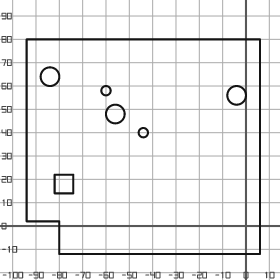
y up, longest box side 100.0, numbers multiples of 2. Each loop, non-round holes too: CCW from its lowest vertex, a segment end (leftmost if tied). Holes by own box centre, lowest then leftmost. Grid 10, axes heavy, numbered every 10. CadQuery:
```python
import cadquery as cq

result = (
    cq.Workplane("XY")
    .moveTo(-80.0, -12.0)
    .lineTo(6.0, -12.0)
    .lineTo(6.0, 80.0)
    .lineTo(-94.0, 80.0)
    .lineTo(-94.0, 2.0)
    .lineTo(-80.0, 2.0)
    .close()
    .moveTo(-82.0, 14.0)
    .lineTo(-74.0, 14.0)
    .lineTo(-74.0, 22.0)
    .lineTo(-82.0, 22.0)
    .close()
    .moveTo(-44.0, 40.0)
    .circle(2.0)
    .moveTo(-56.0, 48.0)
    .circle(4.0)
    .moveTo(-4.0, 56.0)
    .circle(4.0)
    .moveTo(-60.0, 58.0)
    .circle(2.0)
    .moveTo(-84.0, 64.0)
    .circle(4.0)
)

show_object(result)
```